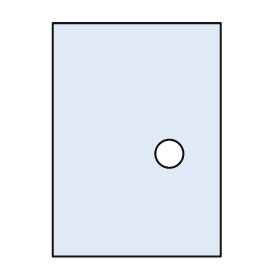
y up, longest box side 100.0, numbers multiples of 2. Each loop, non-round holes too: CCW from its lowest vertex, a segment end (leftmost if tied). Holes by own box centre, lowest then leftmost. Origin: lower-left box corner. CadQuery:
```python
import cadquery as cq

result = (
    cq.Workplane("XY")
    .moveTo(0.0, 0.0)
    .lineTo(72.0, 0.0)
    .lineTo(72.0, 100.0)
    .lineTo(0.0, 100.0)
    .close()
    .moveTo(50.0, 44.0)
    .circle(6.0)
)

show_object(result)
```